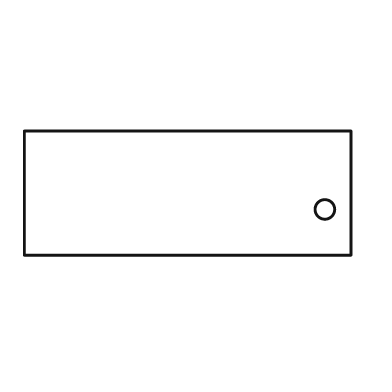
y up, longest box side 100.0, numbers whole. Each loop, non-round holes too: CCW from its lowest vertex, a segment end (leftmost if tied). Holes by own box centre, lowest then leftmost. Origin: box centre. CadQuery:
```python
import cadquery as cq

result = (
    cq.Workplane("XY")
    .moveTo(-50.0, -19.0)
    .lineTo(50.0, -19.0)
    .lineTo(50.0, 19.0)
    .lineTo(-50.0, 19.0)
    .close()
    .moveTo(42.0, -5.0)
    .circle(3.0)
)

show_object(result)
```